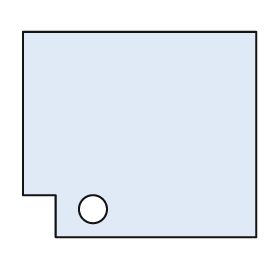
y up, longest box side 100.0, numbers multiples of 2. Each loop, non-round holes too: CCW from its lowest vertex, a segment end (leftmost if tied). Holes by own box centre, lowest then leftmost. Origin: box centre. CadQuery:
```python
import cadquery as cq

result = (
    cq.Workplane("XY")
    .moveTo(-36.0, -44.0)
    .lineTo(50.0, -44.0)
    .lineTo(50.0, 44.0)
    .lineTo(-50.0, 44.0)
    .lineTo(-50.0, -26.0)
    .lineTo(-36.0, -26.0)
    .close()
    .moveTo(-20.0, -32.0)
    .circle(6.0)
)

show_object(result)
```